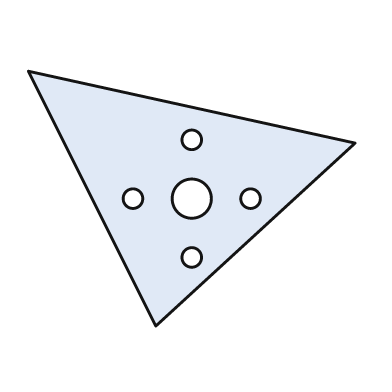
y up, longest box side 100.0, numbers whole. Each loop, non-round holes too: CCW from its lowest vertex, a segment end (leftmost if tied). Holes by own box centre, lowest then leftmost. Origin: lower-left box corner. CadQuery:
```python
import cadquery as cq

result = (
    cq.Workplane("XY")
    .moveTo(39.0, 0.0)
    .lineTo(100.0, 56.0)
    .lineTo(0.0, 78.0)
    .close()
    .moveTo(50.0, 21.0)
    .circle(3.0)
    .moveTo(32.0, 39.0)
    .circle(3.0)
    .moveTo(50.0, 39.0)
    .circle(6.0)
    .moveTo(68.0, 39.0)
    .circle(3.0)
    .moveTo(50.0, 57.0)
    .circle(3.0)
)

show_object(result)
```